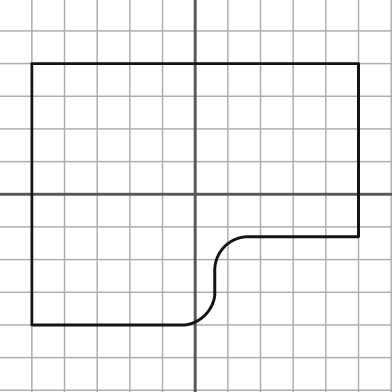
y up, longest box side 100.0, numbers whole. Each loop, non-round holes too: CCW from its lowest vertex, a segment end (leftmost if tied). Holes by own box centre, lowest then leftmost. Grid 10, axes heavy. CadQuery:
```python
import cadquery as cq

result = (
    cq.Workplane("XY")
    .moveTo(-50.0, -40.0)
    .lineTo(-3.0, -40.0)
    .threePointArc((3.0, -37.0), (6.0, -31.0))
    .lineTo(6.0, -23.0)
    .threePointArc((9.0, -16.0), (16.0, -13.0))
    .lineTo(50.0, -13.0)
    .lineTo(50.0, 40.0)
    .lineTo(-50.0, 40.0)
    .close()
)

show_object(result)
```